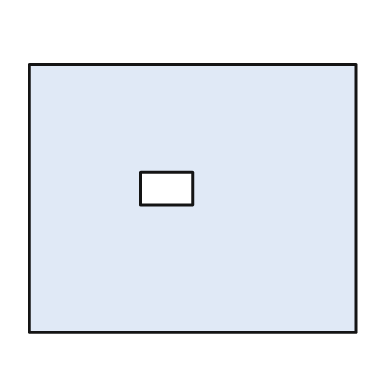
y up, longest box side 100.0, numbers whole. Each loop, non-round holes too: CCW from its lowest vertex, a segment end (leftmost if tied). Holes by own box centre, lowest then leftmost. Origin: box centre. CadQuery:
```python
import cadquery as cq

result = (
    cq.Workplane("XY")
    .moveTo(-50.0, -41.0)
    .lineTo(50.0, -41.0)
    .lineTo(50.0, 41.0)
    .lineTo(-50.0, 41.0)
    .close()
    .moveTo(-16.0, -2.0)
    .lineTo(0.0, -2.0)
    .lineTo(0.0, 8.0)
    .lineTo(-16.0, 8.0)
    .close()
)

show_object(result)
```